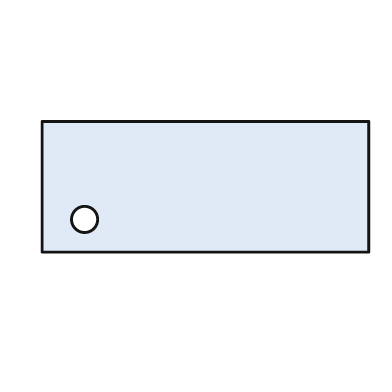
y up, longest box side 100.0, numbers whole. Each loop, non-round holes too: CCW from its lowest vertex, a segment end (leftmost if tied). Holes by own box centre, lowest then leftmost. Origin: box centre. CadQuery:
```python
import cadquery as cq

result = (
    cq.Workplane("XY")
    .moveTo(-50.0, -20.0)
    .lineTo(50.0, -20.0)
    .lineTo(50.0, 20.0)
    .lineTo(-50.0, 20.0)
    .close()
    .moveTo(-37.0, -10.0)
    .circle(4.0)
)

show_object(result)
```